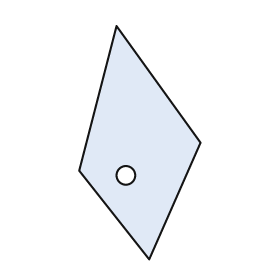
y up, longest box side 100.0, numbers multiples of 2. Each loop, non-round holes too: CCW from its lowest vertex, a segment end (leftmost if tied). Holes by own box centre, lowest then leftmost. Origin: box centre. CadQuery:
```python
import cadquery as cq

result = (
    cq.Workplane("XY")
    .moveTo(4.0, -50.0)
    .lineTo(26.0, 0.0)
    .lineTo(-10.0, 50.0)
    .lineTo(-26.0, -12.0)
    .close()
    .moveTo(-6.0, -14.0)
    .circle(4.0)
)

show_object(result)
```